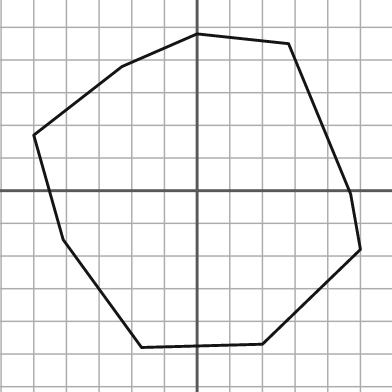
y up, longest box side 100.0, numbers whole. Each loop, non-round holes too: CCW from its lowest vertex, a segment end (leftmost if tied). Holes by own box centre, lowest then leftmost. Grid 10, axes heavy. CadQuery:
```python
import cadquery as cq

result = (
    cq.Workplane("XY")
    .moveTo(-17.0, -48.0)
    .lineTo(20.0, -47.0)
    .lineTo(50.0, -18.0)
    .lineTo(47.0, -1.0)
    .lineTo(28.0, 45.0)
    .lineTo(0.0, 48.0)
    .lineTo(-23.0, 38.0)
    .lineTo(-50.0, 17.0)
    .lineTo(-41.0, -15.0)
    .close()
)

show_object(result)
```